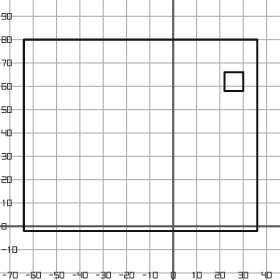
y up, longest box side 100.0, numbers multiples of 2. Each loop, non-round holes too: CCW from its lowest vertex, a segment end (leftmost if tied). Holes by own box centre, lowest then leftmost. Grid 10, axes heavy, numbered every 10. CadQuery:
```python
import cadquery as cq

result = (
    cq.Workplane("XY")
    .moveTo(-64.0, -2.0)
    .lineTo(36.0, -2.0)
    .lineTo(36.0, 80.0)
    .lineTo(-64.0, 80.0)
    .close()
    .moveTo(22.0, 58.0)
    .lineTo(30.0, 58.0)
    .lineTo(30.0, 66.0)
    .lineTo(22.0, 66.0)
    .close()
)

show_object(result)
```